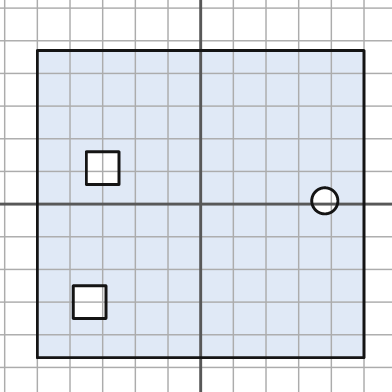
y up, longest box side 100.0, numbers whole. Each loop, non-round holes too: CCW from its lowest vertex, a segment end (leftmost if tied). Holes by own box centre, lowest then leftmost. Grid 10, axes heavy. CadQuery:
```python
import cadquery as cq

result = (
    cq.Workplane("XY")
    .moveTo(-50.0, -47.0)
    .lineTo(50.0, -47.0)
    .lineTo(50.0, 47.0)
    .lineTo(-50.0, 47.0)
    .close()
    .moveTo(-39.0, -35.0)
    .lineTo(-29.0, -35.0)
    .lineTo(-29.0, -25.0)
    .lineTo(-39.0, -25.0)
    .close()
    .moveTo(38.0, 1.0)
    .circle(4.0)
    .moveTo(-35.0, 6.0)
    .lineTo(-25.0, 6.0)
    .lineTo(-25.0, 16.0)
    .lineTo(-35.0, 16.0)
    .close()
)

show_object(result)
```